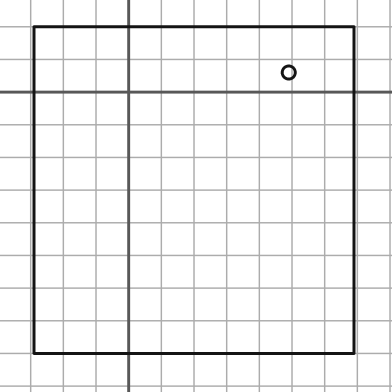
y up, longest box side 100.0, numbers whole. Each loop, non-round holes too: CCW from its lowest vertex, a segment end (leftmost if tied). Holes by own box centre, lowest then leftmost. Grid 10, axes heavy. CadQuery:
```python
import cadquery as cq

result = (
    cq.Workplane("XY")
    .moveTo(-29.0, -80.0)
    .lineTo(69.0, -80.0)
    .lineTo(69.0, 20.0)
    .lineTo(-29.0, 20.0)
    .close()
    .moveTo(49.0, 6.0)
    .circle(2.0)
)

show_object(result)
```